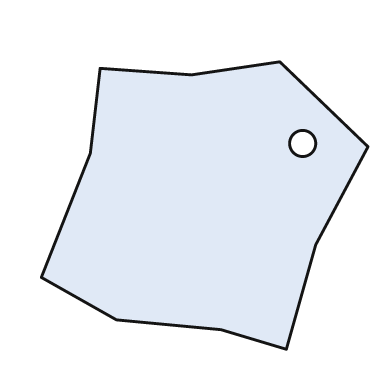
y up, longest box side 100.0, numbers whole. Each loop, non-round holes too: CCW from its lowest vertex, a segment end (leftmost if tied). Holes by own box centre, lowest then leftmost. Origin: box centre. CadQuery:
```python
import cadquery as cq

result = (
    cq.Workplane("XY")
    .moveTo(25.0, -44.0)
    .lineTo(34.0, -12.0)
    .lineTo(50.0, 18.0)
    .lineTo(23.0, 44.0)
    .lineTo(-4.0, 40.0)
    .lineTo(-32.0, 42.0)
    .lineTo(-35.0, 16.0)
    .lineTo(-50.0, -22.0)
    .lineTo(-27.0, -35.0)
    .lineTo(5.0, -38.0)
    .close()
    .moveTo(30.0, 19.0)
    .circle(4.0)
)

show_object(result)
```